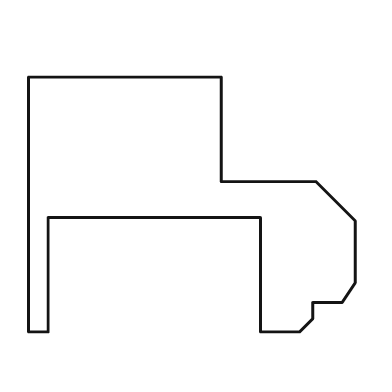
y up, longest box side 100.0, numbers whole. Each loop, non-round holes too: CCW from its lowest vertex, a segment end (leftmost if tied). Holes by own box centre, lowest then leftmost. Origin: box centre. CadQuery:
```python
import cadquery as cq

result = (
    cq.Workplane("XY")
    .moveTo(-50.0, -39.0)
    .lineTo(-44.0, -39.0)
    .lineTo(-44.0, -4.0)
    .lineTo(21.0, -4.0)
    .lineTo(21.0, -39.0)
    .lineTo(33.0, -39.0)
    .lineTo(37.0, -35.0)
    .lineTo(37.0, -30.0)
    .lineTo(46.0, -30.0)
    .lineTo(50.0, -24.0)
    .lineTo(50.0, -5.0)
    .lineTo(38.0, 7.0)
    .lineTo(9.0, 7.0)
    .lineTo(9.0, 39.0)
    .lineTo(-50.0, 39.0)
    .close()
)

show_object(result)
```